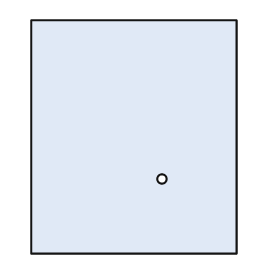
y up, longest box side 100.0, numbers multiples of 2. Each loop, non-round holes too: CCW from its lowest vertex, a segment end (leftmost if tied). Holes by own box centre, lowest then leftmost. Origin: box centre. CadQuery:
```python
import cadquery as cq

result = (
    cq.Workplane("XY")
    .moveTo(-44.0, -50.0)
    .lineTo(44.0, -50.0)
    .lineTo(44.0, 50.0)
    .lineTo(-44.0, 50.0)
    .close()
    .moveTo(12.0, -18.0)
    .circle(2.0)
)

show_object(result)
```